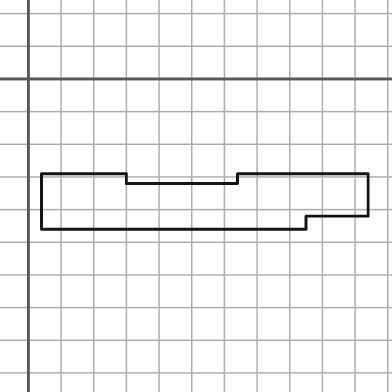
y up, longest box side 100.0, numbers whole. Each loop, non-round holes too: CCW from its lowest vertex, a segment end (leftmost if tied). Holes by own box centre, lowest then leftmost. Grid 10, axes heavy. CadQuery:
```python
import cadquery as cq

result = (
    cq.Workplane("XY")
    .moveTo(4.0, -46.0)
    .lineTo(85.0, -46.0)
    .lineTo(85.0, -42.0)
    .lineTo(104.0, -42.0)
    .lineTo(104.0, -29.0)
    .lineTo(64.0, -29.0)
    .lineTo(64.0, -32.0)
    .lineTo(30.0, -32.0)
    .lineTo(30.0, -29.0)
    .lineTo(4.0, -29.0)
    .close()
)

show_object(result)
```